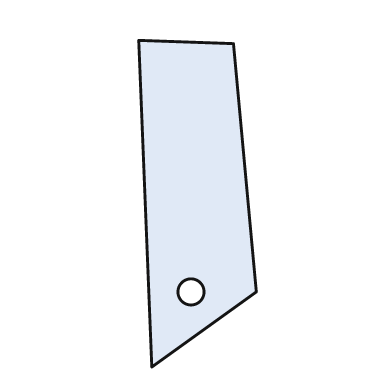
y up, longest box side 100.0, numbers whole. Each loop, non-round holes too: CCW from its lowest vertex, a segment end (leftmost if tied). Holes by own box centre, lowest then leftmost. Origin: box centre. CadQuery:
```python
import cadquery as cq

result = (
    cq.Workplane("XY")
    .moveTo(-14.0, -50.0)
    .lineTo(18.0, -27.0)
    .lineTo(11.0, 49.0)
    .lineTo(-18.0, 50.0)
    .close()
    .moveTo(-2.0, -27.0)
    .circle(4.0)
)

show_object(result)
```